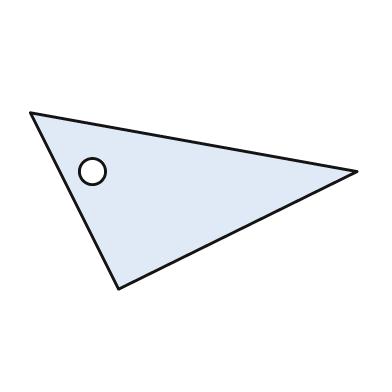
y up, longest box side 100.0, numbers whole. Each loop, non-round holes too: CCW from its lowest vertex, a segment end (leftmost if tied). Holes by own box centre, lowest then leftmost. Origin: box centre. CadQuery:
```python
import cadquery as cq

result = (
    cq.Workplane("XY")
    .moveTo(-23.0, -27.0)
    .lineTo(50.0, 9.0)
    .lineTo(-50.0, 27.0)
    .close()
    .moveTo(-31.0, 9.0)
    .circle(4.0)
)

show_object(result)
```